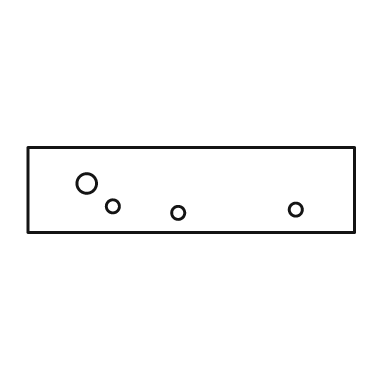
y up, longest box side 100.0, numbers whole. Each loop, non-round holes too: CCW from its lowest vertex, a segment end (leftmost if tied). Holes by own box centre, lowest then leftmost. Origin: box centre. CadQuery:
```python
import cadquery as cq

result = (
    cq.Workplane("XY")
    .moveTo(-50.0, -13.0)
    .lineTo(50.0, -13.0)
    .lineTo(50.0, 13.0)
    .lineTo(-50.0, 13.0)
    .close()
    .moveTo(-4.0, -7.0)
    .circle(2.0)
    .moveTo(32.0, -6.0)
    .circle(2.0)
    .moveTo(-24.0, -5.0)
    .circle(2.0)
    .moveTo(-32.0, 2.0)
    .circle(3.0)
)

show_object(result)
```